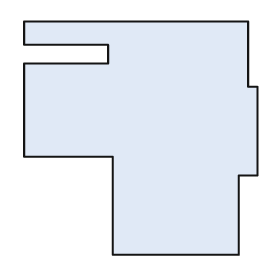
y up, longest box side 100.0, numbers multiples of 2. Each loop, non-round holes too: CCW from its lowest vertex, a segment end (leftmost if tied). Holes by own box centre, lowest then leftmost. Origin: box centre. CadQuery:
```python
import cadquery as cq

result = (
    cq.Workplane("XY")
    .moveTo(-12.0, -50.0)
    .lineTo(42.0, -50.0)
    .lineTo(42.0, -16.0)
    .lineTo(50.0, -16.0)
    .lineTo(50.0, 22.0)
    .lineTo(46.0, 22.0)
    .lineTo(46.0, 50.0)
    .lineTo(-50.0, 50.0)
    .lineTo(-50.0, 40.0)
    .lineTo(-14.0, 40.0)
    .lineTo(-14.0, 32.0)
    .lineTo(-50.0, 32.0)
    .lineTo(-50.0, -8.0)
    .lineTo(-12.0, -8.0)
    .close()
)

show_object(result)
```